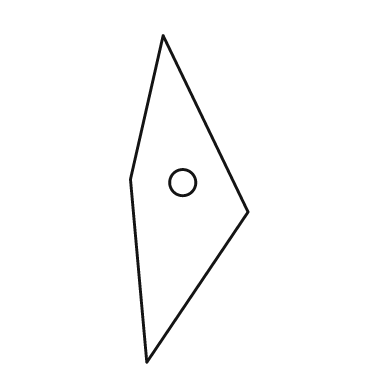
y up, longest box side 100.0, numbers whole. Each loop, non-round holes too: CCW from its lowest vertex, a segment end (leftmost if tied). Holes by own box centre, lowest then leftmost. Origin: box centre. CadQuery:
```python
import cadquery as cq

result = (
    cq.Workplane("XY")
    .moveTo(-13.0, -50.0)
    .lineTo(18.0, -4.0)
    .lineTo(-8.0, 50.0)
    .lineTo(-18.0, 6.0)
    .close()
    .moveTo(-2.0, 5.0)
    .circle(4.0)
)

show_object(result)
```